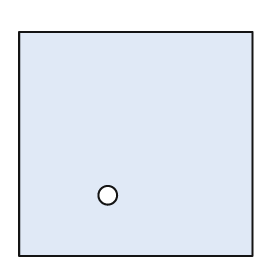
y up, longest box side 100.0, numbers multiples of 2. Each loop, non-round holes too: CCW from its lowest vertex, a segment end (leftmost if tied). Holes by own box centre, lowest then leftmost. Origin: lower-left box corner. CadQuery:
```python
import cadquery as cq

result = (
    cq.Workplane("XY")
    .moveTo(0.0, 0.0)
    .lineTo(100.0, 0.0)
    .lineTo(100.0, 96.0)
    .lineTo(0.0, 96.0)
    .close()
    .moveTo(38.0, 26.0)
    .circle(4.0)
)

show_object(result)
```